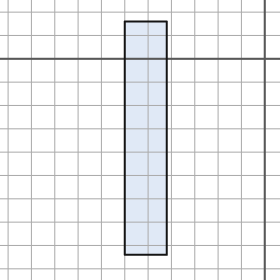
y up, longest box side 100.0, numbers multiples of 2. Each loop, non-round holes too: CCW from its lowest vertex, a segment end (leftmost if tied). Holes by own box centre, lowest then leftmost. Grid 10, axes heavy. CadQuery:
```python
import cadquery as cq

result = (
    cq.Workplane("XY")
    .moveTo(-60.0, -84.0)
    .lineTo(-42.0, -84.0)
    .lineTo(-42.0, 16.0)
    .lineTo(-60.0, 16.0)
    .close()
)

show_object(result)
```